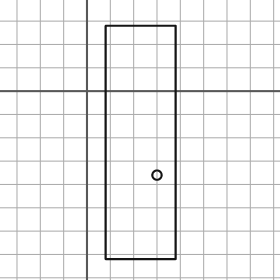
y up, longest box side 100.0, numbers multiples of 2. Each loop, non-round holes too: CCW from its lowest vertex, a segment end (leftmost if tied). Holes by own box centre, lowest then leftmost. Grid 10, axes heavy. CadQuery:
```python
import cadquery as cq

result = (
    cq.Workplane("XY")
    .moveTo(8.0, -72.0)
    .lineTo(38.0, -72.0)
    .lineTo(38.0, 28.0)
    .lineTo(8.0, 28.0)
    .close()
    .moveTo(30.0, -36.0)
    .circle(2.0)
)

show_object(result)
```